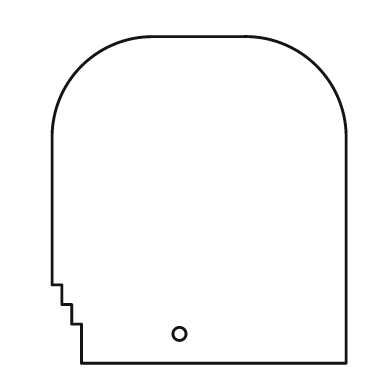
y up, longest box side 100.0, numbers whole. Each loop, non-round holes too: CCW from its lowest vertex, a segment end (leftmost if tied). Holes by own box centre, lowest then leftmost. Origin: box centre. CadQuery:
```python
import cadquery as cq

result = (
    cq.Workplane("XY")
    .moveTo(-36.0, -50.0)
    .lineTo(45.0, -50.0)
    .lineTo(45.0, 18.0)
    .threePointArc((36.0, 41.0), (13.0, 50.0))
    .lineTo(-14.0, 50.0)
    .threePointArc((-36.0, 41.0), (-45.0, 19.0))
    .lineTo(-45.0, -26.0)
    .lineTo(-42.0, -26.0)
    .lineTo(-42.0, -32.0)
    .lineTo(-39.0, -32.0)
    .lineTo(-39.0, -38.0)
    .lineTo(-36.0, -38.0)
    .close()
    .moveTo(-6.0, -41.0)
    .circle(2.0)
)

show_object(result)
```